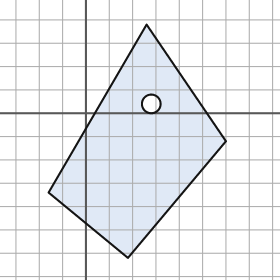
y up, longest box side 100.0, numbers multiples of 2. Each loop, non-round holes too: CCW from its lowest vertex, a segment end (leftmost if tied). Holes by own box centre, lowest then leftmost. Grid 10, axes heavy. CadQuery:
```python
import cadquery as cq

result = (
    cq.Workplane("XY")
    .moveTo(18.0, -62.0)
    .lineTo(60.0, -12.0)
    .lineTo(26.0, 38.0)
    .lineTo(-16.0, -34.0)
    .close()
    .moveTo(28.0, 4.0)
    .circle(4.0)
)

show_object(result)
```